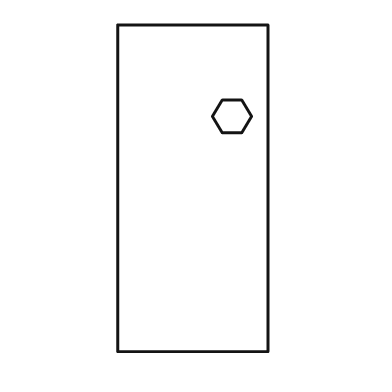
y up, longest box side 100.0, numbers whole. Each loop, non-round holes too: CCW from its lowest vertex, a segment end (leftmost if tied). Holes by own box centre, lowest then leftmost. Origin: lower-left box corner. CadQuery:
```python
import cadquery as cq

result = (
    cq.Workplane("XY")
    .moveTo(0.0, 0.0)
    .lineTo(46.0, 0.0)
    .lineTo(46.0, 100.0)
    .lineTo(0.0, 100.0)
    .close()
    .moveTo(32.0, 67.0)
    .lineTo(38.0, 67.0)
    .lineTo(41.0, 72.0)
    .lineTo(38.0, 77.0)
    .lineTo(32.0, 77.0)
    .lineTo(29.0, 72.0)
    .close()
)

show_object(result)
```